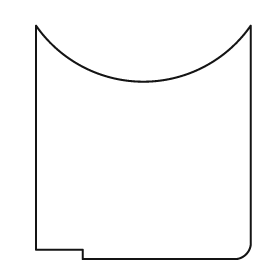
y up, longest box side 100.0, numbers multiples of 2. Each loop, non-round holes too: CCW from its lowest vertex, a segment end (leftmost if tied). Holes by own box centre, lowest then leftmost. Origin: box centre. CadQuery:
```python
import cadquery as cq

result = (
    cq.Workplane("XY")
    .moveTo(-26.0, -50.0)
    .lineTo(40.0, -50.0)
    .threePointArc((44.0, -48.0), (46.0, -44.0))
    .lineTo(46.0, 50.0)
    .threePointArc((0.0, 26.0), (-46.0, 50.0))
    .lineTo(-46.0, -46.0)
    .lineTo(-26.0, -46.0)
    .close()
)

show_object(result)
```